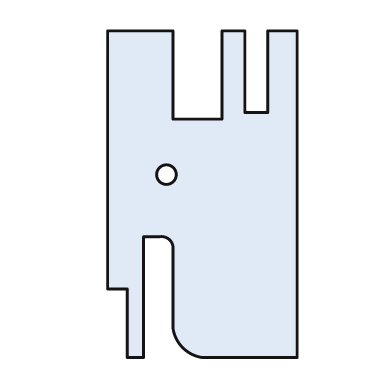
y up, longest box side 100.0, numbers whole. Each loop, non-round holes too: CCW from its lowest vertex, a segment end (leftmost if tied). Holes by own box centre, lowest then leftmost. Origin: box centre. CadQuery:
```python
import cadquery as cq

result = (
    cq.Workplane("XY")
    .moveTo(-23.0, -50.0)
    .lineTo(-18.0, -50.0)
    .lineTo(-18.0, -13.0)
    .lineTo(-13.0, -13.0)
    .threePointArc((-10.0, -14.0), (-9.0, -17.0))
    .lineTo(-9.0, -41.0)
    .threePointArc((-6.0, -47.0), (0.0, -50.0))
    .lineTo(29.0, -50.0)
    .lineTo(29.0, 50.0)
    .lineTo(20.0, 50.0)
    .lineTo(20.0, 25.0)
    .lineTo(13.0, 25.0)
    .lineTo(13.0, 50.0)
    .lineTo(6.0, 50.0)
    .lineTo(6.0, 23.0)
    .lineTo(-9.0, 23.0)
    .lineTo(-9.0, 50.0)
    .lineTo(-29.0, 50.0)
    .lineTo(-29.0, -29.0)
    .lineTo(-23.0, -29.0)
    .close()
    .moveTo(-11.0, 6.0)
    .circle(3.0)
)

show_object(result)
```